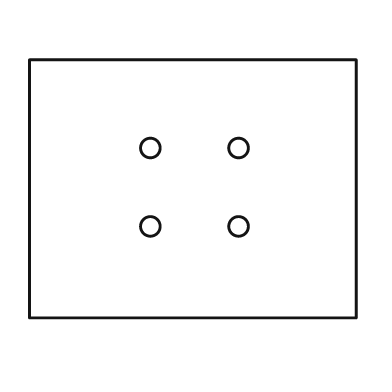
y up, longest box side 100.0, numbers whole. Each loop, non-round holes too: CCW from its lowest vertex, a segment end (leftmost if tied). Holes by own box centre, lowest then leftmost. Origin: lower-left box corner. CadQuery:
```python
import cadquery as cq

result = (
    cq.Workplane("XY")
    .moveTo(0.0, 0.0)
    .lineTo(100.0, 0.0)
    .lineTo(100.0, 79.0)
    .lineTo(0.0, 79.0)
    .close()
    .moveTo(37.0, 28.0)
    .circle(3.0)
    .moveTo(64.0, 28.0)
    .circle(3.0)
    .moveTo(37.0, 52.0)
    .circle(3.0)
    .moveTo(64.0, 52.0)
    .circle(3.0)
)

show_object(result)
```